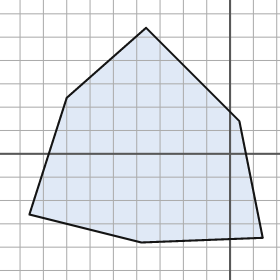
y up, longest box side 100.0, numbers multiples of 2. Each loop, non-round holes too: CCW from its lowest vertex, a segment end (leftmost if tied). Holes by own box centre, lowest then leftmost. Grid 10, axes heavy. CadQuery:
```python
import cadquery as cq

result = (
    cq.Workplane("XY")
    .moveTo(-38.0, -38.0)
    .lineTo(14.0, -36.0)
    .lineTo(4.0, 14.0)
    .lineTo(-36.0, 54.0)
    .lineTo(-70.0, 24.0)
    .lineTo(-86.0, -26.0)
    .close()
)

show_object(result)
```